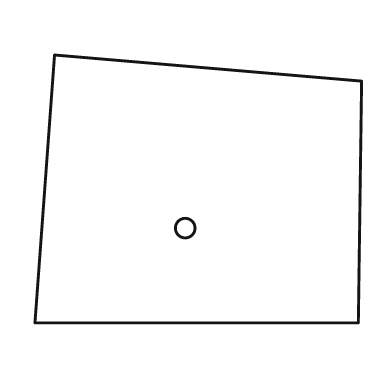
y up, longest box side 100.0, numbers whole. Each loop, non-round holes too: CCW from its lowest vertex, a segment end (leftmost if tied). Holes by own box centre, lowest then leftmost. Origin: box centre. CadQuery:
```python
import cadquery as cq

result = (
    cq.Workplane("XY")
    .moveTo(-50.0, -41.0)
    .lineTo(49.0, -41.0)
    .lineTo(50.0, 33.0)
    .lineTo(-44.0, 41.0)
    .close()
    .moveTo(-4.0, -12.0)
    .circle(3.0)
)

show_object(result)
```